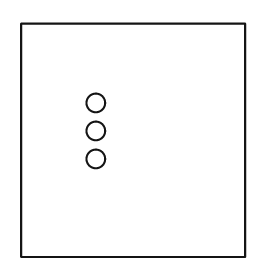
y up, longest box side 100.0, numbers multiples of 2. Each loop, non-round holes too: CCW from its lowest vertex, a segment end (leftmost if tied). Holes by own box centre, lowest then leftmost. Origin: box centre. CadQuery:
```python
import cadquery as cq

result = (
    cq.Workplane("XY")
    .moveTo(-48.0, -50.0)
    .lineTo(48.0, -50.0)
    .lineTo(48.0, 50.0)
    .lineTo(-48.0, 50.0)
    .close()
    .moveTo(-16.0, -8.0)
    .circle(4.0)
    .moveTo(-16.0, 4.0)
    .circle(4.0)
    .moveTo(-16.0, 16.0)
    .circle(4.0)
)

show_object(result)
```